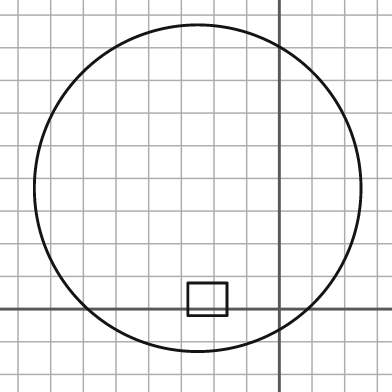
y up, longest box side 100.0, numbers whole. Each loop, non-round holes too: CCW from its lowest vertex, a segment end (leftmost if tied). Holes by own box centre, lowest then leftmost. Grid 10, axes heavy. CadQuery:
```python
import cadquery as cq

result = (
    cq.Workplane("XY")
    .moveTo(-25.0, 37.0)
    .circle(50.0)
    .moveTo(-28.0, -2.0)
    .lineTo(-16.0, -2.0)
    .lineTo(-16.0, 8.0)
    .lineTo(-28.0, 8.0)
    .close()
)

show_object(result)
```